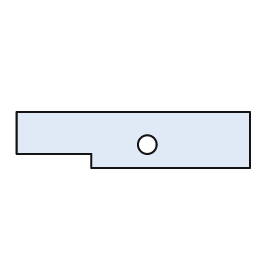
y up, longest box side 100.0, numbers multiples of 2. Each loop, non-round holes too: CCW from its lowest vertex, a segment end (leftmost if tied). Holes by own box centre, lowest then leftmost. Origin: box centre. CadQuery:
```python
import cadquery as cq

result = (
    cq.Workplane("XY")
    .moveTo(-18.0, -12.0)
    .lineTo(50.0, -12.0)
    .lineTo(50.0, 12.0)
    .lineTo(-50.0, 12.0)
    .lineTo(-50.0, -6.0)
    .lineTo(-18.0, -6.0)
    .close()
    .moveTo(6.0, -2.0)
    .circle(4.0)
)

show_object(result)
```